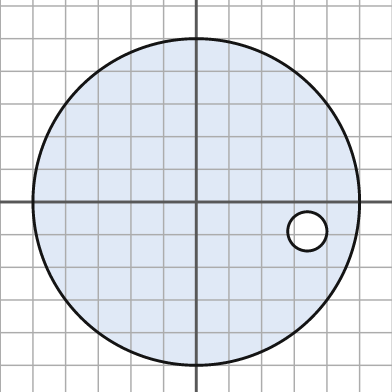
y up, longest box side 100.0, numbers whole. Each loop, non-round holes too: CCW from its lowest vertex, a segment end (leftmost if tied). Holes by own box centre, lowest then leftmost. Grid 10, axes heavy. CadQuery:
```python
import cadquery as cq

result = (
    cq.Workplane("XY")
    .moveTo(0.0, 0.0)
    .circle(50.0)
    .moveTo(34.0, -9.0)
    .circle(6.0)
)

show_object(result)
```